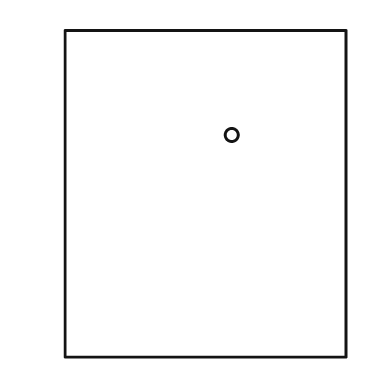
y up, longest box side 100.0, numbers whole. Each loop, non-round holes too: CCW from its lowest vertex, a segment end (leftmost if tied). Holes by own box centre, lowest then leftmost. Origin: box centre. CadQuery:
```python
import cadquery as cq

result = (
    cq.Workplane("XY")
    .moveTo(-43.0, -50.0)
    .lineTo(43.0, -50.0)
    .lineTo(43.0, 50.0)
    .lineTo(-43.0, 50.0)
    .close()
    .moveTo(8.0, 18.0)
    .circle(2.0)
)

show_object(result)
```